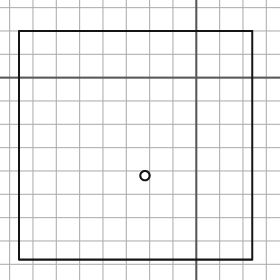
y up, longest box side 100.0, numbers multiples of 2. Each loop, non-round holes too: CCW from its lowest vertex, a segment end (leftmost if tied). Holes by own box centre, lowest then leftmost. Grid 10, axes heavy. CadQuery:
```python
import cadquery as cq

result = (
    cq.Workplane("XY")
    .moveTo(-76.0, -78.0)
    .lineTo(24.0, -78.0)
    .lineTo(24.0, 20.0)
    .lineTo(-76.0, 20.0)
    .close()
    .moveTo(-22.0, -42.0)
    .circle(2.0)
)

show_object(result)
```